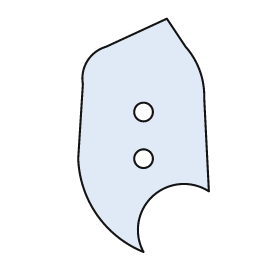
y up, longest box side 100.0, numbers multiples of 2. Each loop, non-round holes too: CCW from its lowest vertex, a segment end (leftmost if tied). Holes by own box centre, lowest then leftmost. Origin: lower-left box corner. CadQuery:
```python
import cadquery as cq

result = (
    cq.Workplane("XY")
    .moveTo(28.0, 0.0)
    .threePointArc((32.0, 24.0), (56.0, 26.0))
    .lineTo(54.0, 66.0)
    .threePointArc((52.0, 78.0), (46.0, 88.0))
    .lineTo(38.0, 100.0)
    .lineTo(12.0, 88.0)
    .threePointArc((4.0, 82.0), (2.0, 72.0))
    .lineTo(0.0, 40.0)
    .threePointArc((8.0, 16.0), (28.0, 0.0))
    .close()
    .moveTo(28.0, 40.0)
    .circle(4.0)
    .moveTo(28.0, 60.0)
    .circle(4.0)
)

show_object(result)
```